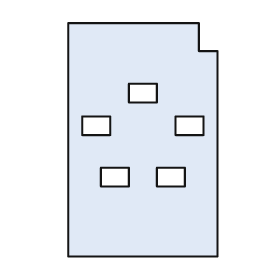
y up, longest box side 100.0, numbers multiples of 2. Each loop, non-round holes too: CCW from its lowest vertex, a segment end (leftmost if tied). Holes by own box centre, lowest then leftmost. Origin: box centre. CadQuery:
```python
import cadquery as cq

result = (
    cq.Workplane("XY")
    .moveTo(-32.0, -50.0)
    .lineTo(32.0, -50.0)
    .lineTo(32.0, 38.0)
    .lineTo(24.0, 38.0)
    .lineTo(24.0, 50.0)
    .lineTo(-32.0, 50.0)
    .close()
    .moveTo(-18.0, -20.0)
    .lineTo(-6.0, -20.0)
    .lineTo(-6.0, -12.0)
    .lineTo(-18.0, -12.0)
    .close()
    .moveTo(6.0, -20.0)
    .lineTo(18.0, -20.0)
    .lineTo(18.0, -12.0)
    .lineTo(6.0, -12.0)
    .close()
    .moveTo(-26.0, 2.0)
    .lineTo(-14.0, 2.0)
    .lineTo(-14.0, 10.0)
    .lineTo(-26.0, 10.0)
    .close()
    .moveTo(14.0, 2.0)
    .lineTo(26.0, 2.0)
    .lineTo(26.0, 10.0)
    .lineTo(14.0, 10.0)
    .close()
    .moveTo(-6.0, 16.0)
    .lineTo(6.0, 16.0)
    .lineTo(6.0, 24.0)
    .lineTo(-6.0, 24.0)
    .close()
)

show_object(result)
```